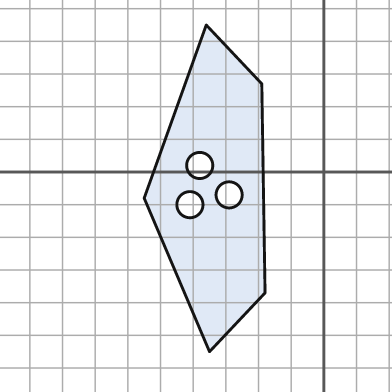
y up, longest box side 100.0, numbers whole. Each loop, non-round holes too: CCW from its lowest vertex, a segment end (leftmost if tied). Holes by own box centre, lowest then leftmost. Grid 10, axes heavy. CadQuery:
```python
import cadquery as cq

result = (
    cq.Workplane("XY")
    .moveTo(-35.0, -55.0)
    .lineTo(-18.0, -37.0)
    .lineTo(-19.0, 27.0)
    .lineTo(-36.0, 45.0)
    .lineTo(-55.0, -8.0)
    .close()
    .moveTo(-41.0, -10.0)
    .circle(4.0)
    .moveTo(-29.0, -7.0)
    .circle(4.0)
    .moveTo(-38.0, 2.0)
    .circle(4.0)
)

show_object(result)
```